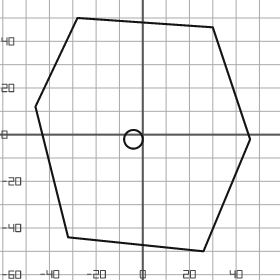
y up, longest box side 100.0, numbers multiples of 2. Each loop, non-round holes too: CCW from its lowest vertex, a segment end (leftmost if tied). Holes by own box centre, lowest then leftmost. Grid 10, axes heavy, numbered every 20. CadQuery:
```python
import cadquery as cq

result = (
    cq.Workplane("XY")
    .moveTo(26.0, -50.0)
    .lineTo(46.0, -2.0)
    .lineTo(30.0, 46.0)
    .lineTo(-28.0, 50.0)
    .lineTo(-46.0, 12.0)
    .lineTo(-32.0, -44.0)
    .close()
    .moveTo(-4.0, -2.0)
    .circle(4.0)
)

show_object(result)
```